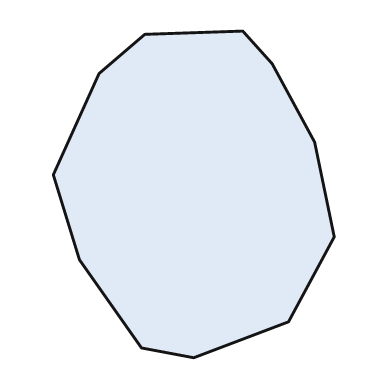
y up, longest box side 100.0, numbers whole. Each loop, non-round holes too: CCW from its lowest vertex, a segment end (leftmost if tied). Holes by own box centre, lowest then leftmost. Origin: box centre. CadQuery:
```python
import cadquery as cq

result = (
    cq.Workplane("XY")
    .moveTo(0.0, -50.0)
    .lineTo(29.0, -39.0)
    .lineTo(43.0, -13.0)
    .lineTo(37.0, 16.0)
    .lineTo(24.0, 40.0)
    .lineTo(15.0, 50.0)
    .lineTo(-15.0, 49.0)
    .lineTo(-29.0, 37.0)
    .lineTo(-43.0, 6.0)
    .lineTo(-35.0, -20.0)
    .lineTo(-16.0, -47.0)
    .close()
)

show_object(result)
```